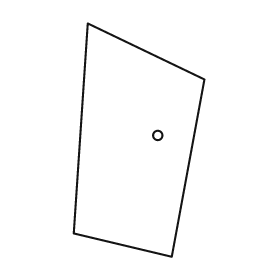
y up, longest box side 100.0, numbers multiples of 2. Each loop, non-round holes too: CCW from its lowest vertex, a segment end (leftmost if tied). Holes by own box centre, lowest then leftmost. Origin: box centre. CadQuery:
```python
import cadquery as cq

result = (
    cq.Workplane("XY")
    .moveTo(14.0, -50.0)
    .lineTo(28.0, 26.0)
    .lineTo(-22.0, 50.0)
    .lineTo(-28.0, -40.0)
    .close()
    .moveTo(8.0, 2.0)
    .circle(2.0)
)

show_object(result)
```